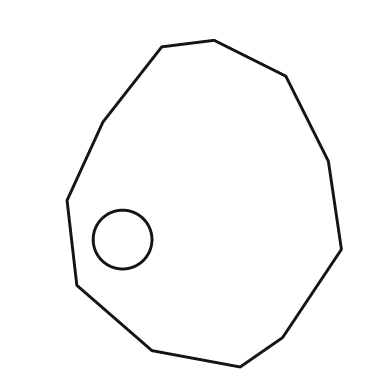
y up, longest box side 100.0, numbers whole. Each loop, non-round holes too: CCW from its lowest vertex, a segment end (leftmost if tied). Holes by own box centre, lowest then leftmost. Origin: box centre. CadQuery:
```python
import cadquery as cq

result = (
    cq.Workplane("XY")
    .moveTo(11.0, -50.0)
    .lineTo(24.0, -41.0)
    .lineTo(42.0, -14.0)
    .lineTo(38.0, 13.0)
    .lineTo(25.0, 39.0)
    .lineTo(3.0, 50.0)
    .lineTo(-13.0, 48.0)
    .lineTo(-31.0, 25.0)
    .lineTo(-42.0, 1.0)
    .lineTo(-39.0, -25.0)
    .lineTo(-16.0, -45.0)
    .close()
    .moveTo(-25.0, -11.0)
    .circle(9.0)
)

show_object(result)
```